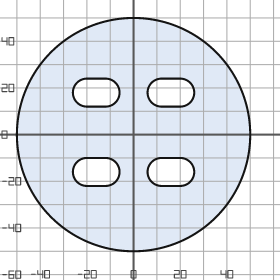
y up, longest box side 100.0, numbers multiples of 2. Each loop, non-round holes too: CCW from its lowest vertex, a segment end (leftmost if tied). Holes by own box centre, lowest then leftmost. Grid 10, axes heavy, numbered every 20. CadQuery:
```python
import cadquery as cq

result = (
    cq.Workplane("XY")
    .moveTo(0.0, 0.0)
    .circle(50.0)
    .moveTo(-20.0, -22.0)
    .lineTo(-12.0, -22.0)
    .threePointArc((-6.0, -16.0), (-12.0, -10.0))
    .lineTo(-20.0, -10.0)
    .threePointArc((-26.0, -16.0), (-20.0, -22.0))
    .close()
    .moveTo(12.0, -22.0)
    .lineTo(20.0, -22.0)
    .threePointArc((26.0, -16.0), (20.0, -10.0))
    .lineTo(12.0, -10.0)
    .threePointArc((6.0, -16.0), (12.0, -22.0))
    .close()
    .moveTo(-20.0, 12.0)
    .lineTo(-12.0, 12.0)
    .threePointArc((-6.0, 18.0), (-12.0, 24.0))
    .lineTo(-20.0, 24.0)
    .threePointArc((-26.0, 18.0), (-20.0, 12.0))
    .close()
    .moveTo(12.0, 12.0)
    .lineTo(20.0, 12.0)
    .threePointArc((26.0, 18.0), (20.0, 24.0))
    .lineTo(12.0, 24.0)
    .threePointArc((6.0, 18.0), (12.0, 12.0))
    .close()
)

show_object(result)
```